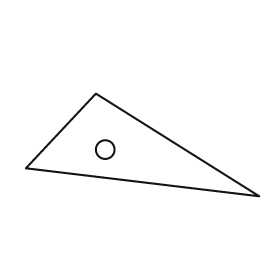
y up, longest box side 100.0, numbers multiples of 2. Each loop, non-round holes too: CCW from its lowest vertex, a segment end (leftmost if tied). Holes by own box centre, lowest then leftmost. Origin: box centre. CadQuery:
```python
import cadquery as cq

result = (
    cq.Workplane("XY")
    .moveTo(50.0, -22.0)
    .lineTo(-20.0, 22.0)
    .lineTo(-50.0, -10.0)
    .close()
    .moveTo(-16.0, -2.0)
    .circle(4.0)
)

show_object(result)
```